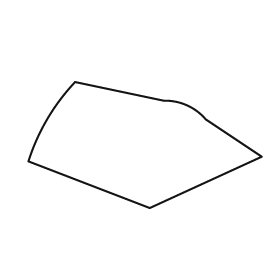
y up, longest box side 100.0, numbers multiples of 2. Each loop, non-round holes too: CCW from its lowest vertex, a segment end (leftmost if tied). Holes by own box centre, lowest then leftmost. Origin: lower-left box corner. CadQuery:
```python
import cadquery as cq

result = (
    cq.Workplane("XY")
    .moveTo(52.0, 0.0)
    .lineTo(100.0, 22.0)
    .lineTo(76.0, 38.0)
    .threePointArc((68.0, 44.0), (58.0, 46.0))
    .lineTo(20.0, 54.0)
    .threePointArc((8.0, 38.0), (0.0, 20.0))
    .close()
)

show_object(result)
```